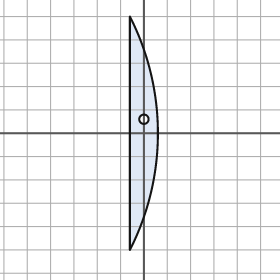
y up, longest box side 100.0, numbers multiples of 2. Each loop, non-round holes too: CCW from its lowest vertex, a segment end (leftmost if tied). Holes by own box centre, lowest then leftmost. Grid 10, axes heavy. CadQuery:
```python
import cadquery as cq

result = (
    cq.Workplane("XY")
    .moveTo(-6.0, -50.0)
    .threePointArc((6.0, 0.0), (-6.0, 50.0))
    .close()
    .moveTo(0.0, 6.0)
    .circle(2.0)
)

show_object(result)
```